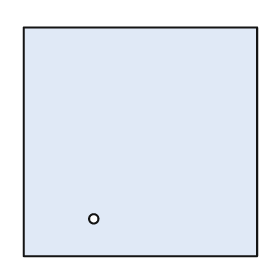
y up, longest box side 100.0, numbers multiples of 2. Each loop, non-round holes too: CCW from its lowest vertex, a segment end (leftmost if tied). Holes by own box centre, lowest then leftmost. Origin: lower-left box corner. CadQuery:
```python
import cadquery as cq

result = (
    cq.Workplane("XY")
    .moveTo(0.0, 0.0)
    .lineTo(100.0, 0.0)
    .lineTo(100.0, 98.0)
    .lineTo(0.0, 98.0)
    .close()
    .moveTo(30.0, 16.0)
    .circle(2.0)
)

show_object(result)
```